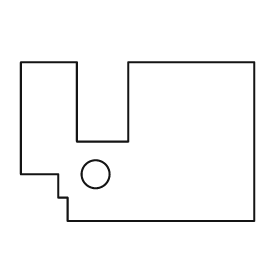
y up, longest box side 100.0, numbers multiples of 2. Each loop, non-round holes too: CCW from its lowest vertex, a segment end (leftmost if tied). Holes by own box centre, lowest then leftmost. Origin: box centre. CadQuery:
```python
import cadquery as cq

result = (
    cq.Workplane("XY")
    .moveTo(-30.0, -34.0)
    .lineTo(50.0, -34.0)
    .lineTo(50.0, 34.0)
    .lineTo(-4.0, 34.0)
    .lineTo(-4.0, 0.0)
    .lineTo(-26.0, 0.0)
    .lineTo(-26.0, 34.0)
    .lineTo(-50.0, 34.0)
    .lineTo(-50.0, -14.0)
    .lineTo(-34.0, -14.0)
    .lineTo(-34.0, -24.0)
    .lineTo(-30.0, -24.0)
    .close()
    .moveTo(-18.0, -14.0)
    .circle(6.0)
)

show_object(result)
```